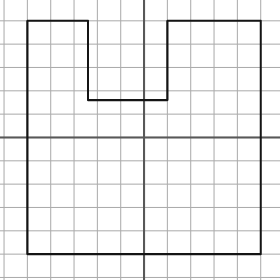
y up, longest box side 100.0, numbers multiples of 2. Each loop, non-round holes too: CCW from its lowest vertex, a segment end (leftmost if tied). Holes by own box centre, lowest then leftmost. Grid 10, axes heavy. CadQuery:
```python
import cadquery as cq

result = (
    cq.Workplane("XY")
    .moveTo(-50.0, -50.0)
    .lineTo(50.0, -50.0)
    .lineTo(50.0, 50.0)
    .lineTo(10.0, 50.0)
    .lineTo(10.0, 16.0)
    .lineTo(-24.0, 16.0)
    .lineTo(-24.0, 50.0)
    .lineTo(-50.0, 50.0)
    .close()
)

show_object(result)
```